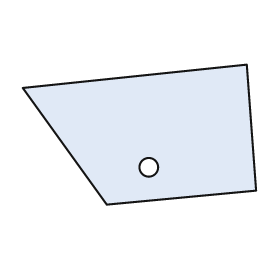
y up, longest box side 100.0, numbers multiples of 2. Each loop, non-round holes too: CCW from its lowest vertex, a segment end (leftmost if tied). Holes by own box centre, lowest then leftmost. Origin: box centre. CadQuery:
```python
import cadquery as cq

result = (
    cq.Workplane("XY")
    .moveTo(-14.0, -30.0)
    .lineTo(50.0, -24.0)
    .lineTo(46.0, 30.0)
    .lineTo(-50.0, 20.0)
    .close()
    .moveTo(4.0, -14.0)
    .circle(4.0)
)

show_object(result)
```